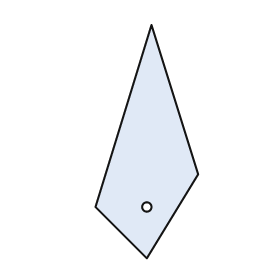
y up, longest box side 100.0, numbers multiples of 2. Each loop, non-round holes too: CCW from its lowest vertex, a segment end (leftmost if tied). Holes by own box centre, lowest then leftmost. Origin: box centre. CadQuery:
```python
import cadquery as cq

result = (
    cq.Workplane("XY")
    .moveTo(0.0, -50.0)
    .lineTo(22.0, -14.0)
    .lineTo(2.0, 50.0)
    .lineTo(-22.0, -28.0)
    .close()
    .moveTo(0.0, -28.0)
    .circle(2.0)
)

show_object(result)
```